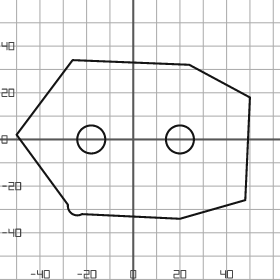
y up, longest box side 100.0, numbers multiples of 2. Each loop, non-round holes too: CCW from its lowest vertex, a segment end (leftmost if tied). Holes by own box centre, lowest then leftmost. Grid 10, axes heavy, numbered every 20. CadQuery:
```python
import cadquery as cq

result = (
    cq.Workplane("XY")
    .moveTo(20.0, -34.0)
    .lineTo(48.0, -26.0)
    .lineTo(50.0, 18.0)
    .lineTo(24.0, 32.0)
    .lineTo(-26.0, 34.0)
    .lineTo(-50.0, 2.0)
    .lineTo(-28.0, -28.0)
    .threePointArc((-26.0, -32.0), (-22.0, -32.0))
    .close()
    .moveTo(-18.0, 0.0)
    .circle(6.0)
    .moveTo(20.0, 0.0)
    .circle(6.0)
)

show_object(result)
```